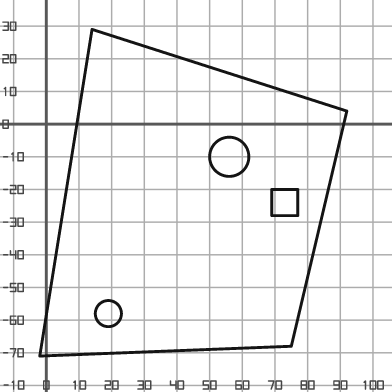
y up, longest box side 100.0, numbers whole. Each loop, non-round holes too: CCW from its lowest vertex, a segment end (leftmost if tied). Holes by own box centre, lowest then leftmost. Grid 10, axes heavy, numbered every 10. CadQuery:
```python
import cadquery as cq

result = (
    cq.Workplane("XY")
    .moveTo(-2.0, -71.0)
    .lineTo(75.0, -68.0)
    .lineTo(92.0, 4.0)
    .lineTo(14.0, 29.0)
    .close()
    .moveTo(19.0, -58.0)
    .circle(4.0)
    .moveTo(69.0, -28.0)
    .lineTo(77.0, -28.0)
    .lineTo(77.0, -20.0)
    .lineTo(69.0, -20.0)
    .close()
    .moveTo(56.0, -10.0)
    .circle(6.0)
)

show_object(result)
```